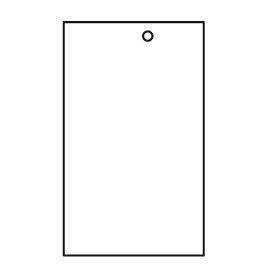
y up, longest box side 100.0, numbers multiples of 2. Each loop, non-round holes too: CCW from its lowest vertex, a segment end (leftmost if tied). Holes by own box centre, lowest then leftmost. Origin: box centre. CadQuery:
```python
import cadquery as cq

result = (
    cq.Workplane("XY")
    .moveTo(-30.0, -50.0)
    .lineTo(30.0, -50.0)
    .lineTo(30.0, 50.0)
    .lineTo(-30.0, 50.0)
    .close()
    .moveTo(6.0, 44.0)
    .circle(2.0)
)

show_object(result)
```